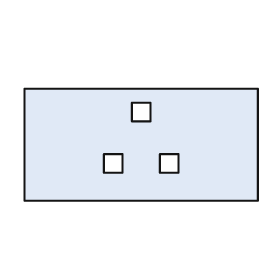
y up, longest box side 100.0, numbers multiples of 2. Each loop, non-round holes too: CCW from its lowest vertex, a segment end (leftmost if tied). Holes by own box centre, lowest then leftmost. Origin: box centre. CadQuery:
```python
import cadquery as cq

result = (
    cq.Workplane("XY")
    .moveTo(-50.0, -24.0)
    .lineTo(50.0, -24.0)
    .lineTo(50.0, 24.0)
    .lineTo(-50.0, 24.0)
    .close()
    .moveTo(-16.0, -12.0)
    .lineTo(-8.0, -12.0)
    .lineTo(-8.0, -4.0)
    .lineTo(-16.0, -4.0)
    .close()
    .moveTo(8.0, -12.0)
    .lineTo(16.0, -12.0)
    .lineTo(16.0, -4.0)
    .lineTo(8.0, -4.0)
    .close()
    .moveTo(-4.0, 10.0)
    .lineTo(4.0, 10.0)
    .lineTo(4.0, 18.0)
    .lineTo(-4.0, 18.0)
    .close()
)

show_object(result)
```